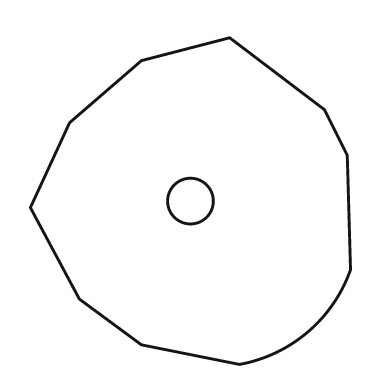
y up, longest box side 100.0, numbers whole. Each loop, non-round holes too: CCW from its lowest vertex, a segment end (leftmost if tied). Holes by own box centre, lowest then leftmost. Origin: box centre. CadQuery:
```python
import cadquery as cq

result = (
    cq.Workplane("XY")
    .moveTo(15.0, -50.0)
    .threePointArc((36.0, -40.0), (49.0, -21.0))
    .lineTo(48.0, 14.0)
    .lineTo(41.0, 28.0)
    .lineTo(12.0, 50.0)
    .lineTo(-15.0, 43.0)
    .lineTo(-37.0, 24.0)
    .lineTo(-49.0, -2.0)
    .lineTo(-34.0, -30.0)
    .lineTo(-15.0, -44.0)
    .close()
    .moveTo(0.0, 0.0)
    .circle(7.0)
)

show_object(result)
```